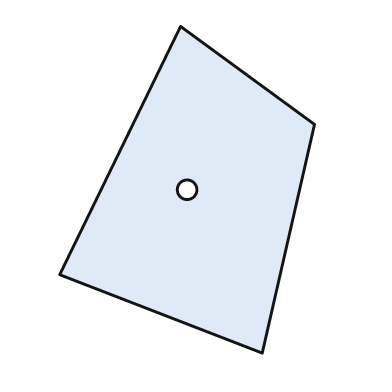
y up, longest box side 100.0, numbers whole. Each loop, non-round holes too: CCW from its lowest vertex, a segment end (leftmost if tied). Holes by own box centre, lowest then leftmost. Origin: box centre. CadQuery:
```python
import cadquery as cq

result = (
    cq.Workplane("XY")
    .moveTo(23.0, -50.0)
    .lineTo(39.0, 20.0)
    .lineTo(-2.0, 50.0)
    .lineTo(-39.0, -26.0)
    .close()
    .moveTo(0.0, 0.0)
    .circle(3.0)
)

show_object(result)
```